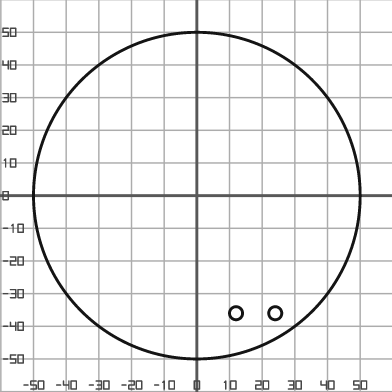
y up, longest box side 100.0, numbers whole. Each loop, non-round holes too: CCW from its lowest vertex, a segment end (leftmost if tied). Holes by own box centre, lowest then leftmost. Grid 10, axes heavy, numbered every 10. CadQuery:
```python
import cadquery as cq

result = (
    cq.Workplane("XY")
    .moveTo(0.0, 0.0)
    .circle(50.0)
    .moveTo(12.0, -36.0)
    .circle(2.0)
    .moveTo(24.0, -36.0)
    .circle(2.0)
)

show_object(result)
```